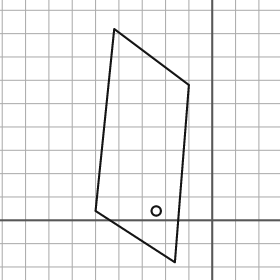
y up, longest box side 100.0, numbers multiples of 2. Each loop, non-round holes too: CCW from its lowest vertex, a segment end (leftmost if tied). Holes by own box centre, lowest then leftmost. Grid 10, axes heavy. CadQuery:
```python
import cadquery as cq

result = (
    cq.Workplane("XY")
    .moveTo(-16.0, -18.0)
    .lineTo(-10.0, 58.0)
    .lineTo(-42.0, 82.0)
    .lineTo(-50.0, 4.0)
    .close()
    .moveTo(-24.0, 4.0)
    .circle(2.0)
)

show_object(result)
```